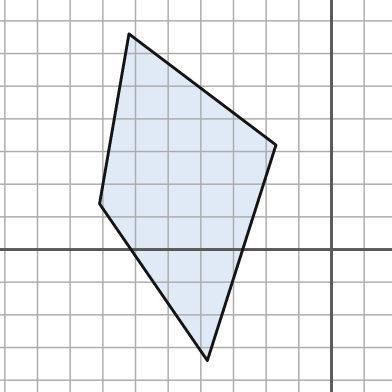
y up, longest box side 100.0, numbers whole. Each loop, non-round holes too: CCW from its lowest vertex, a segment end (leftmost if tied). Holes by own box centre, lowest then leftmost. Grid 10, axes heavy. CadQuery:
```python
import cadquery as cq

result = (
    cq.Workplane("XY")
    .moveTo(-38.0, -34.0)
    .lineTo(-17.0, 32.0)
    .lineTo(-62.0, 66.0)
    .lineTo(-71.0, 14.0)
    .close()
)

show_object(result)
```